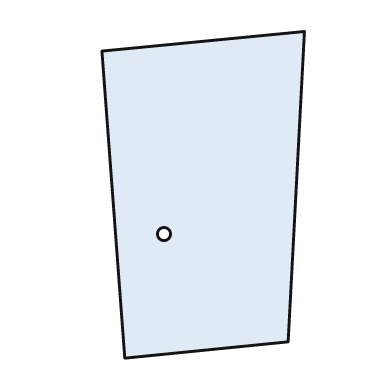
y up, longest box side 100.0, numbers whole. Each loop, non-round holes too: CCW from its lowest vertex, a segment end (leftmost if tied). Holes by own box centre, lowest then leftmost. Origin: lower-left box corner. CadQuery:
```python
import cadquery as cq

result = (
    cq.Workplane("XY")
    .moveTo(7.0, 0.0)
    .lineTo(57.0, 5.0)
    .lineTo(62.0, 100.0)
    .lineTo(0.0, 94.0)
    .close()
    .moveTo(19.0, 38.0)
    .circle(2.0)
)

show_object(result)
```